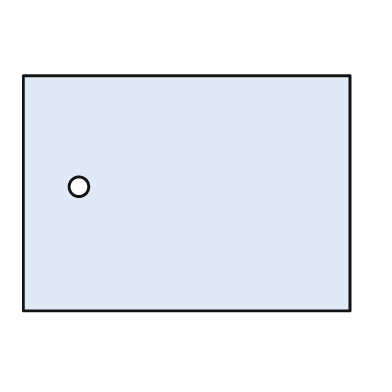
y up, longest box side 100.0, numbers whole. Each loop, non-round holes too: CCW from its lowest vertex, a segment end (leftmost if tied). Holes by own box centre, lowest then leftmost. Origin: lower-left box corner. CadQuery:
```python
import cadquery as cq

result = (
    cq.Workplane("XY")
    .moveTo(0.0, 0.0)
    .lineTo(100.0, 0.0)
    .lineTo(100.0, 72.0)
    .lineTo(0.0, 72.0)
    .close()
    .moveTo(17.0, 38.0)
    .circle(3.0)
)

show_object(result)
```